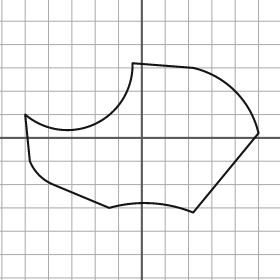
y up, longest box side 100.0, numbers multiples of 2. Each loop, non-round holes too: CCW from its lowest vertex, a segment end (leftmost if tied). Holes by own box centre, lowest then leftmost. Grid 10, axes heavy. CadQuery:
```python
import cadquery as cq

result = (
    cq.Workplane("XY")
    .moveTo(22.0, -32.0)
    .lineTo(50.0, 2.0)
    .threePointArc((40.0, 20.0), (22.0, 30.0))
    .lineTo(-4.0, 32.0)
    .threePointArc((-20.0, 6.0), (-50.0, 10.0))
    .lineTo(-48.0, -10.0)
    .threePointArc((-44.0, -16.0), (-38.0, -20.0))
    .lineTo(-14.0, -30.0)
    .threePointArc((4.0, -28.0), (22.0, -32.0))
    .close()
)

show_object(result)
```